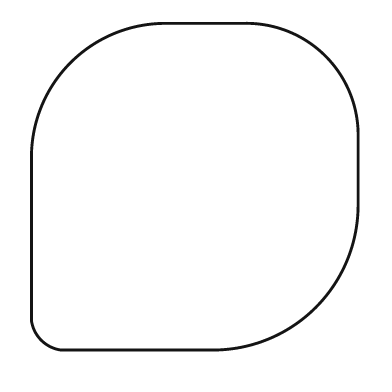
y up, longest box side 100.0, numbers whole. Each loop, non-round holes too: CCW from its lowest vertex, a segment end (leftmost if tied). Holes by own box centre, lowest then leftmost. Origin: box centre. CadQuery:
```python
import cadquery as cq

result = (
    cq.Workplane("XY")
    .moveTo(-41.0, -50.0)
    .lineTo(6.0, -50.0)
    .threePointArc((37.0, -37.0), (50.0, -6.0))
    .lineTo(50.0, 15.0)
    .threePointArc((40.0, 40.0), (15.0, 50.0))
    .lineTo(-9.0, 50.0)
    .threePointArc((-38.0, 38.0), (-50.0, 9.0))
    .lineTo(-50.0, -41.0)
    .threePointArc((-47.0, -47.0), (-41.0, -50.0))
    .close()
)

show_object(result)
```